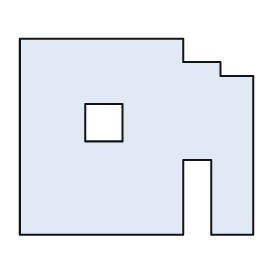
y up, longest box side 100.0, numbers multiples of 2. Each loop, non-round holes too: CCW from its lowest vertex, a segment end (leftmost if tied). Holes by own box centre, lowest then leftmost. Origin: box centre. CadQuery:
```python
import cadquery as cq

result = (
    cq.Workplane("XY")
    .moveTo(-50.0, -42.0)
    .lineTo(20.0, -42.0)
    .lineTo(20.0, -10.0)
    .lineTo(32.0, -10.0)
    .lineTo(32.0, -42.0)
    .lineTo(50.0, -42.0)
    .lineTo(50.0, 26.0)
    .lineTo(36.0, 26.0)
    .lineTo(36.0, 32.0)
    .lineTo(20.0, 32.0)
    .lineTo(20.0, 42.0)
    .lineTo(-50.0, 42.0)
    .close()
    .moveTo(-22.0, -2.0)
    .lineTo(-6.0, -2.0)
    .lineTo(-6.0, 14.0)
    .lineTo(-22.0, 14.0)
    .close()
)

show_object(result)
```